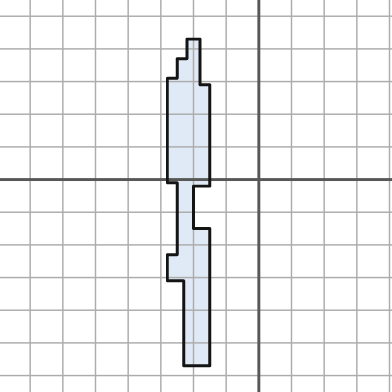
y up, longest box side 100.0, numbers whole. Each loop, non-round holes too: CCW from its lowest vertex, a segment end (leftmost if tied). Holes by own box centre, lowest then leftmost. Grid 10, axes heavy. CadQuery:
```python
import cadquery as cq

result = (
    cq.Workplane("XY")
    .moveTo(-23.0, -57.0)
    .lineTo(-15.0, -57.0)
    .lineTo(-15.0, -15.0)
    .lineTo(-20.0, -15.0)
    .lineTo(-20.0, -2.0)
    .lineTo(-15.0, -2.0)
    .lineTo(-15.0, 29.0)
    .lineTo(-18.0, 29.0)
    .lineTo(-18.0, 43.0)
    .lineTo(-22.0, 43.0)
    .lineTo(-22.0, 37.0)
    .lineTo(-25.0, 37.0)
    .lineTo(-25.0, 31.0)
    .lineTo(-28.0, 31.0)
    .lineTo(-28.0, -1.0)
    .lineTo(-25.0, -1.0)
    .lineTo(-25.0, -23.0)
    .lineTo(-28.0, -23.0)
    .lineTo(-28.0, -31.0)
    .lineTo(-23.0, -31.0)
    .close()
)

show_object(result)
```